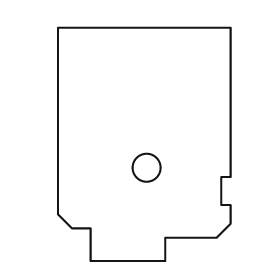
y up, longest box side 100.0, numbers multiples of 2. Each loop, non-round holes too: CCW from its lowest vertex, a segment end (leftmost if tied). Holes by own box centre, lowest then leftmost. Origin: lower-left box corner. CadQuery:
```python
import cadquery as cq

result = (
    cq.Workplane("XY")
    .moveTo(14.0, 0.0)
    .lineTo(46.0, 0.0)
    .lineTo(46.0, 10.0)
    .lineTo(68.0, 10.0)
    .lineTo(74.0, 16.0)
    .lineTo(74.0, 24.0)
    .lineTo(70.0, 24.0)
    .lineTo(70.0, 36.0)
    .lineTo(74.0, 36.0)
    .lineTo(74.0, 100.0)
    .lineTo(0.0, 100.0)
    .lineTo(0.0, 20.0)
    .lineTo(6.0, 14.0)
    .lineTo(14.0, 14.0)
    .close()
    .moveTo(38.0, 40.0)
    .circle(6.0)
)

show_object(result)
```